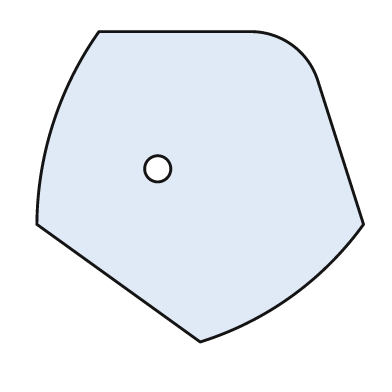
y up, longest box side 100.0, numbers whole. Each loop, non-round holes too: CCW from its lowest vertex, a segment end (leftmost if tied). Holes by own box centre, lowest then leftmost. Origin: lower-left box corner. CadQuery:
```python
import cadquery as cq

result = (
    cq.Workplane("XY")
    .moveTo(50.0, 0.0)
    .threePointArc((78.0, 14.0), (100.0, 36.0))
    .lineTo(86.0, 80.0)
    .threePointArc((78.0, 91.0), (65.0, 95.0))
    .lineTo(19.0, 95.0)
    .threePointArc((5.0, 67.0), (0.0, 36.0))
    .close()
    .moveTo(37.0, 53.0)
    .circle(4.0)
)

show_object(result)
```